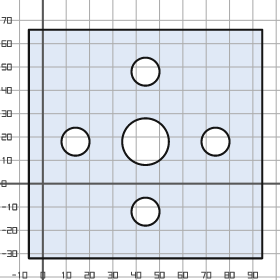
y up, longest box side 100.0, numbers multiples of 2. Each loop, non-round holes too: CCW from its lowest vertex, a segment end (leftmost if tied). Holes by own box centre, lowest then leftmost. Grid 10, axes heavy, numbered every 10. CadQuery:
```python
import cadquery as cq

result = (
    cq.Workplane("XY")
    .moveTo(-6.0, -32.0)
    .lineTo(94.0, -32.0)
    .lineTo(94.0, 66.0)
    .lineTo(-6.0, 66.0)
    .close()
    .moveTo(44.0, -12.0)
    .circle(6.0)
    .moveTo(14.0, 18.0)
    .circle(6.0)
    .moveTo(44.0, 18.0)
    .circle(10.0)
    .moveTo(74.0, 18.0)
    .circle(6.0)
    .moveTo(44.0, 48.0)
    .circle(6.0)
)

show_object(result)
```